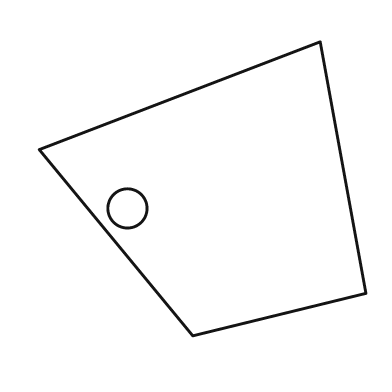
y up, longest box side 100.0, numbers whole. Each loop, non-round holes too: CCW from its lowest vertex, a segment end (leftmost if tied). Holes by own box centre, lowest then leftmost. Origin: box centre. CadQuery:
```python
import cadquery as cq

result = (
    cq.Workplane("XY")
    .moveTo(-3.0, -45.0)
    .lineTo(50.0, -32.0)
    .lineTo(36.0, 45.0)
    .lineTo(-50.0, 12.0)
    .close()
    .moveTo(-23.0, -6.0)
    .circle(6.0)
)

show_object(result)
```